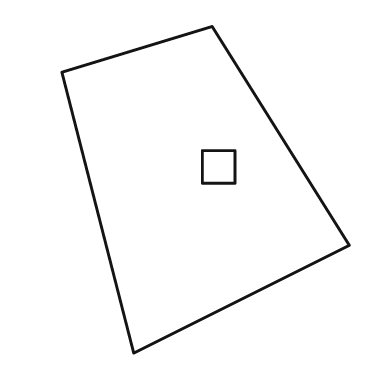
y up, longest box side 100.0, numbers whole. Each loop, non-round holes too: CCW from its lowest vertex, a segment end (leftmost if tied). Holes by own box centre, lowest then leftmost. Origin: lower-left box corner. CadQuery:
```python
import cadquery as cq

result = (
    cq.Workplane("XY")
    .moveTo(22.0, 0.0)
    .lineTo(88.0, 33.0)
    .lineTo(46.0, 100.0)
    .lineTo(0.0, 86.0)
    .close()
    .moveTo(43.0, 52.0)
    .lineTo(53.0, 52.0)
    .lineTo(53.0, 62.0)
    .lineTo(43.0, 62.0)
    .close()
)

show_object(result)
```